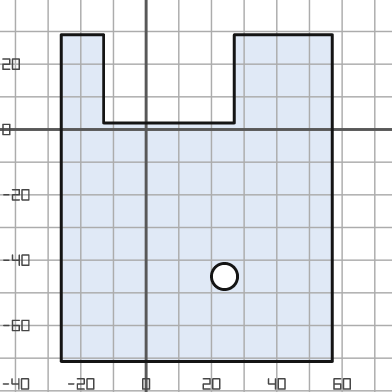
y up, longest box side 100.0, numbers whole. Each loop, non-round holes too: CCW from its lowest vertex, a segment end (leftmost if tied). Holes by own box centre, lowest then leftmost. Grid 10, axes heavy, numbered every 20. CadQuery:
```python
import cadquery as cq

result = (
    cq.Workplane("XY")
    .moveTo(-26.0, -71.0)
    .lineTo(57.0, -71.0)
    .lineTo(57.0, 29.0)
    .lineTo(27.0, 29.0)
    .lineTo(27.0, 2.0)
    .lineTo(-13.0, 2.0)
    .lineTo(-13.0, 29.0)
    .lineTo(-26.0, 29.0)
    .close()
    .moveTo(24.0, -45.0)
    .circle(4.0)
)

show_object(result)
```